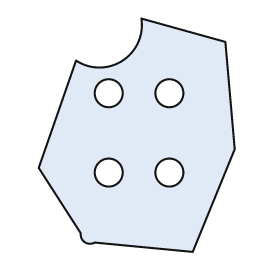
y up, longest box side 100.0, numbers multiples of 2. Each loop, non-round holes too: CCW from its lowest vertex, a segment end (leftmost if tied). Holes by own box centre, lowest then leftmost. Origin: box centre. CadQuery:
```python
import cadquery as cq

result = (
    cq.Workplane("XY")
    .moveTo(24.0, -50.0)
    .lineTo(42.0, -6.0)
    .lineTo(38.0, 40.0)
    .lineTo(2.0, 50.0)
    .threePointArc((-6.0, 32.0), (-26.0, 32.0))
    .lineTo(-42.0, -14.0)
    .lineTo(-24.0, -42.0)
    .threePointArc((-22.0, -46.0), (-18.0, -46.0))
    .close()
    .moveTo(-12.0, -16.0)
    .circle(6.0)
    .moveTo(14.0, -16.0)
    .circle(6.0)
    .moveTo(-12.0, 18.0)
    .circle(6.0)
    .moveTo(14.0, 18.0)
    .circle(6.0)
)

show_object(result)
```